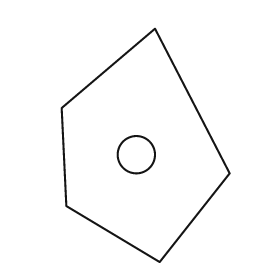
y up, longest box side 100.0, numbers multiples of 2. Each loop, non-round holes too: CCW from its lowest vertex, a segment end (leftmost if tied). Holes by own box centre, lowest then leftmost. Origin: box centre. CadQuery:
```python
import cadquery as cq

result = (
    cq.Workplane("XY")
    .moveTo(6.0, -50.0)
    .lineTo(36.0, -12.0)
    .lineTo(4.0, 50.0)
    .lineTo(-36.0, 16.0)
    .lineTo(-34.0, -26.0)
    .close()
    .moveTo(-4.0, -4.0)
    .circle(8.0)
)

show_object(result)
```